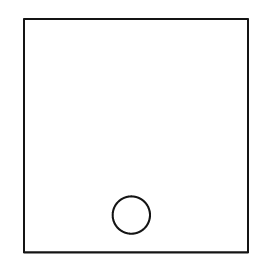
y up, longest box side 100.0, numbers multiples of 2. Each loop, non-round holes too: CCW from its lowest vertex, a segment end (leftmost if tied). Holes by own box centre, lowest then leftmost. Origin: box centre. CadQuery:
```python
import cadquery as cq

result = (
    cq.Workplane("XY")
    .moveTo(-48.0, -50.0)
    .lineTo(48.0, -50.0)
    .lineTo(48.0, 50.0)
    .lineTo(-48.0, 50.0)
    .close()
    .moveTo(-2.0, -34.0)
    .circle(8.0)
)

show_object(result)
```